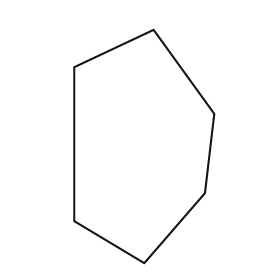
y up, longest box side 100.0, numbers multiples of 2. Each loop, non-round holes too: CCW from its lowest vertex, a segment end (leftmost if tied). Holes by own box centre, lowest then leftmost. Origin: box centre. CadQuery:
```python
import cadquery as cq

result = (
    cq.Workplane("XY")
    .moveTo(0.0, -50.0)
    .lineTo(26.0, -20.0)
    .lineTo(30.0, 14.0)
    .lineTo(4.0, 50.0)
    .lineTo(-30.0, 34.0)
    .lineTo(-30.0, -32.0)
    .close()
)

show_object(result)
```